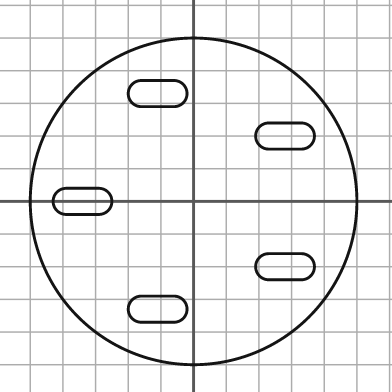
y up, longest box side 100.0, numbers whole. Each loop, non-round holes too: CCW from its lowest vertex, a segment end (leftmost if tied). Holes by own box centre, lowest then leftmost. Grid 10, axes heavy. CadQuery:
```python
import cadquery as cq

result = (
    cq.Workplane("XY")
    .moveTo(0.0, 0.0)
    .circle(50.0)
    .moveTo(-16.0, -37.0)
    .lineTo(-6.0, -37.0)
    .threePointArc((-2.0, -33.0), (-6.0, -29.0))
    .lineTo(-16.0, -29.0)
    .threePointArc((-20.0, -33.0), (-16.0, -37.0))
    .close()
    .moveTo(23.0, -24.0)
    .lineTo(33.0, -24.0)
    .threePointArc((37.0, -20.0), (33.0, -16.0))
    .lineTo(23.0, -16.0)
    .threePointArc((19.0, -20.0), (23.0, -24.0))
    .close()
    .moveTo(-39.0, -4.0)
    .lineTo(-29.0, -4.0)
    .threePointArc((-25.0, 0.0), (-29.0, 4.0))
    .lineTo(-39.0, 4.0)
    .threePointArc((-43.0, 0.0), (-39.0, -4.0))
    .close()
    .moveTo(23.0, 16.0)
    .lineTo(33.0, 16.0)
    .threePointArc((37.0, 20.0), (33.0, 24.0))
    .lineTo(23.0, 24.0)
    .threePointArc((19.0, 20.0), (23.0, 16.0))
    .close()
    .moveTo(-16.0, 29.0)
    .lineTo(-6.0, 29.0)
    .threePointArc((-2.0, 33.0), (-6.0, 37.0))
    .lineTo(-16.0, 37.0)
    .threePointArc((-20.0, 33.0), (-16.0, 29.0))
    .close()
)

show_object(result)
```